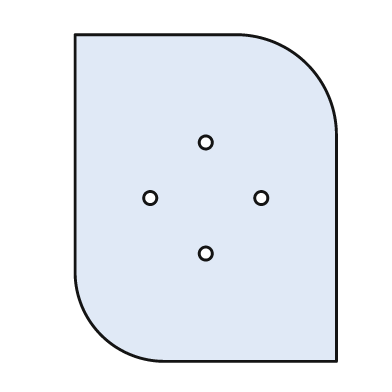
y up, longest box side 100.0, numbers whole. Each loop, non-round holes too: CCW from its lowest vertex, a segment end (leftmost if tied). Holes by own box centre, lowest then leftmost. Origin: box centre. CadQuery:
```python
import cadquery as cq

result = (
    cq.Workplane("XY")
    .moveTo(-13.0, -50.0)
    .lineTo(40.0, -50.0)
    .lineTo(40.0, 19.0)
    .threePointArc((31.0, 41.0), (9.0, 50.0))
    .lineTo(-40.0, 50.0)
    .lineTo(-40.0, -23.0)
    .threePointArc((-32.0, -42.0), (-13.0, -50.0))
    .close()
    .moveTo(0.0, -17.0)
    .circle(2.0)
    .moveTo(-17.0, 0.0)
    .circle(2.0)
    .moveTo(17.0, 0.0)
    .circle(2.0)
    .moveTo(0.0, 17.0)
    .circle(2.0)
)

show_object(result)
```